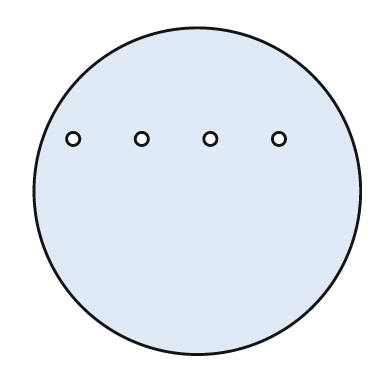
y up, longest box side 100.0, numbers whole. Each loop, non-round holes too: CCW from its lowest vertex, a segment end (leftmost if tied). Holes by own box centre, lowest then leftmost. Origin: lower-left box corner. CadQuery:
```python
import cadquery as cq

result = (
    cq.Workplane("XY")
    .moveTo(50.0, 50.0)
    .circle(50.0)
    .moveTo(12.0, 66.0)
    .circle(2.0)
    .moveTo(33.0, 66.0)
    .circle(2.0)
    .moveTo(54.0, 66.0)
    .circle(2.0)
    .moveTo(75.0, 66.0)
    .circle(2.0)
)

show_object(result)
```